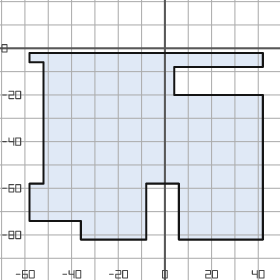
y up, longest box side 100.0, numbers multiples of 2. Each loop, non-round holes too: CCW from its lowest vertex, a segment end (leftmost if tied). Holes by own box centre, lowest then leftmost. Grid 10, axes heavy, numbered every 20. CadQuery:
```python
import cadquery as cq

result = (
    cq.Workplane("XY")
    .moveTo(-36.0, -82.0)
    .lineTo(-8.0, -82.0)
    .lineTo(-8.0, -58.0)
    .lineTo(6.0, -58.0)
    .lineTo(6.0, -82.0)
    .lineTo(42.0, -82.0)
    .lineTo(42.0, -20.0)
    .lineTo(4.0, -20.0)
    .lineTo(4.0, -8.0)
    .lineTo(42.0, -8.0)
    .lineTo(42.0, -2.0)
    .lineTo(-58.0, -2.0)
    .lineTo(-58.0, -6.0)
    .lineTo(-52.0, -6.0)
    .lineTo(-52.0, -58.0)
    .lineTo(-58.0, -58.0)
    .lineTo(-58.0, -74.0)
    .lineTo(-36.0, -74.0)
    .close()
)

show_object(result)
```